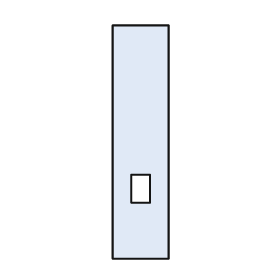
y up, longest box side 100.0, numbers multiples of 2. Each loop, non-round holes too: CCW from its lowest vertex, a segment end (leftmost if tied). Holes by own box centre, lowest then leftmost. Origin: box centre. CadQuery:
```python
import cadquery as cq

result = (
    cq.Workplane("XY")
    .moveTo(-12.0, -50.0)
    .lineTo(12.0, -50.0)
    .lineTo(12.0, 50.0)
    .lineTo(-12.0, 50.0)
    .close()
    .moveTo(-4.0, -26.0)
    .lineTo(4.0, -26.0)
    .lineTo(4.0, -14.0)
    .lineTo(-4.0, -14.0)
    .close()
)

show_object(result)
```